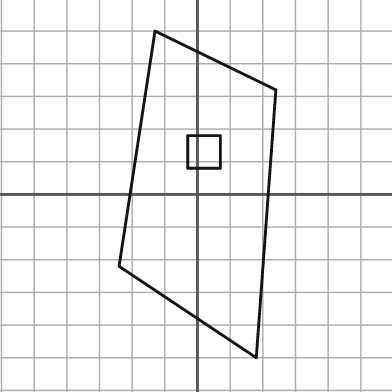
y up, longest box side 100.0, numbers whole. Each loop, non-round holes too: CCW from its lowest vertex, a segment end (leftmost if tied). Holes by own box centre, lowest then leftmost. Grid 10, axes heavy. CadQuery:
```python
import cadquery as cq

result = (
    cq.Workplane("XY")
    .moveTo(18.0, -50.0)
    .lineTo(24.0, 32.0)
    .lineTo(-13.0, 50.0)
    .lineTo(-24.0, -22.0)
    .close()
    .moveTo(-3.0, 8.0)
    .lineTo(7.0, 8.0)
    .lineTo(7.0, 18.0)
    .lineTo(-3.0, 18.0)
    .close()
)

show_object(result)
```